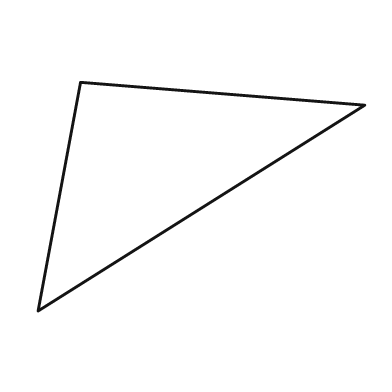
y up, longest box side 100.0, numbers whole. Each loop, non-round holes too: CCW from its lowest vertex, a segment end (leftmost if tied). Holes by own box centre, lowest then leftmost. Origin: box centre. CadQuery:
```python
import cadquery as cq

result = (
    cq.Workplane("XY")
    .moveTo(-50.0, -35.0)
    .lineTo(50.0, 28.0)
    .lineTo(-37.0, 35.0)
    .close()
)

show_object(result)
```